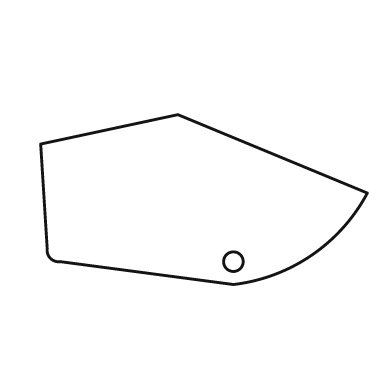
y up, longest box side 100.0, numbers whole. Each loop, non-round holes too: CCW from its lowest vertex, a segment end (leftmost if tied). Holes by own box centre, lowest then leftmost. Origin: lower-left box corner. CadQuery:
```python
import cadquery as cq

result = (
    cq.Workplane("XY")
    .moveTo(59.0, 0.0)
    .threePointArc((83.0, 9.0), (100.0, 28.0))
    .lineTo(42.0, 52.0)
    .lineTo(0.0, 43.0)
    .lineTo(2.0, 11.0)
    .threePointArc((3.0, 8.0), (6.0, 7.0))
    .close()
    .moveTo(59.0, 7.0)
    .circle(3.0)
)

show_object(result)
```